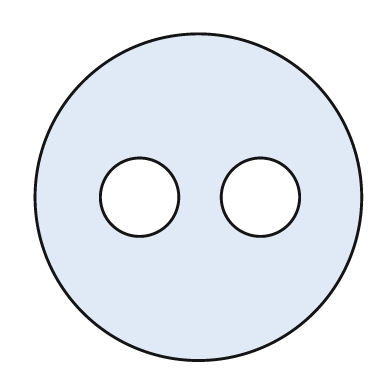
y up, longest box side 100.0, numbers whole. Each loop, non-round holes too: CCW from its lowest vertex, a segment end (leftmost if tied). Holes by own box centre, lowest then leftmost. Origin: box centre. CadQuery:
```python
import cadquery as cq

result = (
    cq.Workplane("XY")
    .moveTo(0.0, 0.0)
    .circle(50.0)
    .moveTo(-18.0, 0.0)
    .circle(12.0)
    .moveTo(19.0, 0.0)
    .circle(12.0)
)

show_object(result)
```